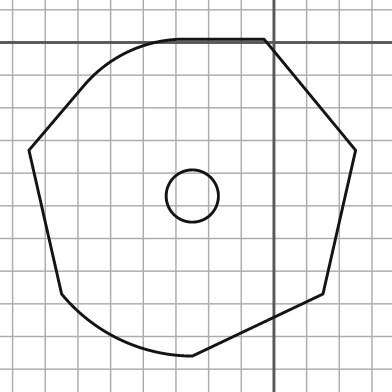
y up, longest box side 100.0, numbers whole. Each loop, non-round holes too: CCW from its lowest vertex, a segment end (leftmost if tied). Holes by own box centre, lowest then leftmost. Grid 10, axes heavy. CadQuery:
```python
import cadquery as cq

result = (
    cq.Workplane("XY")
    .moveTo(-25.0, -96.0)
    .lineTo(15.0, -77.0)
    .lineTo(25.0, -33.0)
    .lineTo(-3.0, 1.0)
    .lineTo(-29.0, 1.0)
    .threePointArc((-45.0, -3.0), (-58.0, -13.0))
    .lineTo(-75.0, -33.0)
    .lineTo(-65.0, -77.0)
    .threePointArc((-47.0, -91.0), (-25.0, -96.0))
    .close()
    .moveTo(-25.0, -47.0)
    .circle(8.0)
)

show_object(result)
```